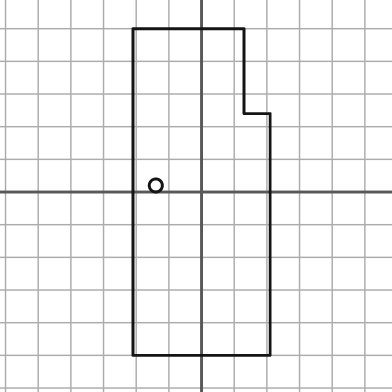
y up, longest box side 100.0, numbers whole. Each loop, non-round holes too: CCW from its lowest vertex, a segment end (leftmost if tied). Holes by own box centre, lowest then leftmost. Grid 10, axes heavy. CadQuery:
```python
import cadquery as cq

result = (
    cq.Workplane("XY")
    .moveTo(-21.0, -50.0)
    .lineTo(21.0, -50.0)
    .lineTo(21.0, 24.0)
    .lineTo(13.0, 24.0)
    .lineTo(13.0, 50.0)
    .lineTo(-21.0, 50.0)
    .close()
    .moveTo(-14.0, 2.0)
    .circle(2.0)
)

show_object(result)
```